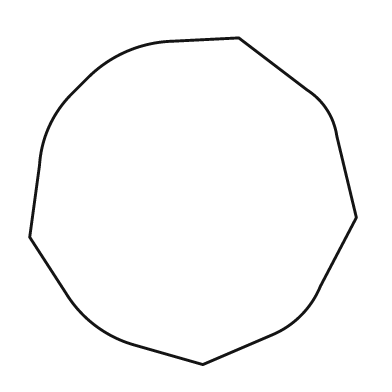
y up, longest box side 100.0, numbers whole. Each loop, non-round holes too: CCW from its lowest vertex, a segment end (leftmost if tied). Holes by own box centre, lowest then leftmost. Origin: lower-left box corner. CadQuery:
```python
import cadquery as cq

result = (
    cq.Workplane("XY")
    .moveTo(53.0, 0.0)
    .lineTo(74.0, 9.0)
    .threePointArc((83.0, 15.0), (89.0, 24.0))
    .lineTo(100.0, 45.0)
    .lineTo(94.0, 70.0)
    .threePointArc((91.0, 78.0), (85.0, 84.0))
    .lineTo(64.0, 100.0)
    .lineTo(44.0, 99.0)
    .threePointArc((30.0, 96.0), (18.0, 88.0))
    .lineTo(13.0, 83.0)
    .threePointArc((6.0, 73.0), (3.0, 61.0))
    .lineTo(0.0, 39.0)
    .lineTo(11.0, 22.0)
    .threePointArc((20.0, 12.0), (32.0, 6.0))
    .close()
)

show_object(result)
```